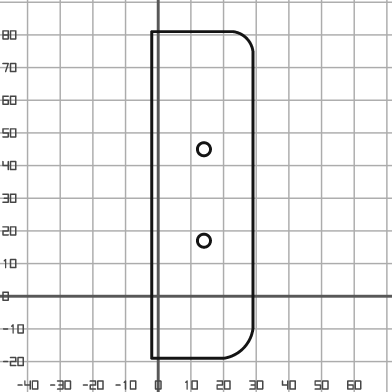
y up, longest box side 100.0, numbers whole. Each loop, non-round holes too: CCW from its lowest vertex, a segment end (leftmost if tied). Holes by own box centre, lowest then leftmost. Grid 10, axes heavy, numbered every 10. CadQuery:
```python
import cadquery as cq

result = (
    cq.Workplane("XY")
    .moveTo(-2.0, -19.0)
    .lineTo(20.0, -19.0)
    .threePointArc((26.0, -16.0), (29.0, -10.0))
    .lineTo(29.0, 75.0)
    .threePointArc((27.0, 79.0), (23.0, 81.0))
    .lineTo(-2.0, 81.0)
    .close()
    .moveTo(14.0, 17.0)
    .circle(2.0)
    .moveTo(14.0, 45.0)
    .circle(2.0)
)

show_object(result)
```